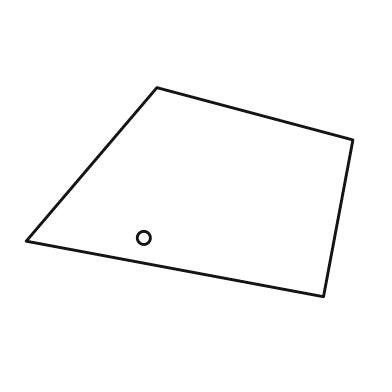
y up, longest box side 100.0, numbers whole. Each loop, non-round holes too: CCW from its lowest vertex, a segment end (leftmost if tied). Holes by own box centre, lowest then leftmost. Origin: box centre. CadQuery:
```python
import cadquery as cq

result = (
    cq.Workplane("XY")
    .moveTo(41.0, -32.0)
    .lineTo(50.0, 16.0)
    .lineTo(-10.0, 32.0)
    .lineTo(-50.0, -15.0)
    .close()
    .moveTo(-14.0, -14.0)
    .circle(2.0)
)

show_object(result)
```